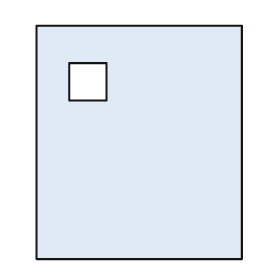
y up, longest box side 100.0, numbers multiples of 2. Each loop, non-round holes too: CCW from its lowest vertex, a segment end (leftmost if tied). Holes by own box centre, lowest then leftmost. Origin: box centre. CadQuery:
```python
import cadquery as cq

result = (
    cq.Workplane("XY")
    .moveTo(-44.0, -50.0)
    .lineTo(44.0, -50.0)
    .lineTo(44.0, 50.0)
    .lineTo(-44.0, 50.0)
    .close()
    .moveTo(-30.0, 18.0)
    .lineTo(-14.0, 18.0)
    .lineTo(-14.0, 34.0)
    .lineTo(-30.0, 34.0)
    .close()
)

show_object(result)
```